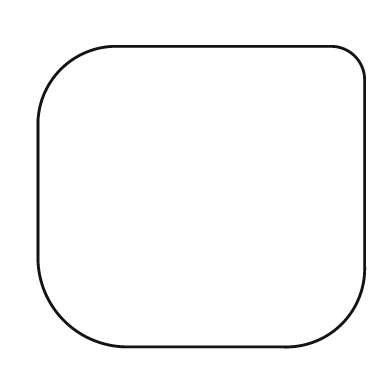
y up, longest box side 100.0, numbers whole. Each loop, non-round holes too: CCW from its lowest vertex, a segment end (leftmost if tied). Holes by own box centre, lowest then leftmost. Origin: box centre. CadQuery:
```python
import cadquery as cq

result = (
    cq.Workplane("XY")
    .moveTo(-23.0, -46.0)
    .lineTo(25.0, -46.0)
    .threePointArc((43.0, -39.0), (50.0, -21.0))
    .lineTo(50.0, 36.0)
    .threePointArc((47.0, 43.0), (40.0, 46.0))
    .lineTo(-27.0, 46.0)
    .threePointArc((-43.0, 39.0), (-50.0, 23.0))
    .lineTo(-50.0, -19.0)
    .threePointArc((-42.0, -38.0), (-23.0, -46.0))
    .close()
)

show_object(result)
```